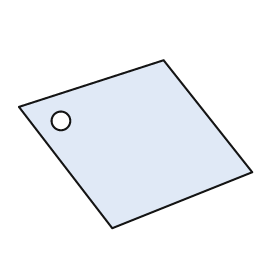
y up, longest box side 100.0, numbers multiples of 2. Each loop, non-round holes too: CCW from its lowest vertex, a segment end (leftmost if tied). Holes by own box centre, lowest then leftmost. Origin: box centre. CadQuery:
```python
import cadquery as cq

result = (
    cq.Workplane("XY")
    .moveTo(-10.0, -36.0)
    .lineTo(50.0, -12.0)
    .lineTo(12.0, 36.0)
    .lineTo(-50.0, 16.0)
    .close()
    .moveTo(-32.0, 10.0)
    .circle(4.0)
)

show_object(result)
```